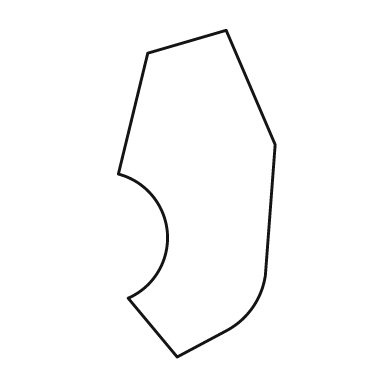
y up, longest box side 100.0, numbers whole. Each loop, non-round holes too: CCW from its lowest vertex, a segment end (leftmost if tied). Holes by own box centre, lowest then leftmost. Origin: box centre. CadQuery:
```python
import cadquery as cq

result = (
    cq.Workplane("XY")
    .moveTo(-6.0, -50.0)
    .lineTo(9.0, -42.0)
    .threePointArc((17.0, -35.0), (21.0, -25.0))
    .lineTo(24.0, 15.0)
    .lineTo(9.0, 50.0)
    .lineTo(-15.0, 43.0)
    .lineTo(-24.0, 6.0)
    .threePointArc((-9.0, -12.0), (-21.0, -32.0))
    .close()
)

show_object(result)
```